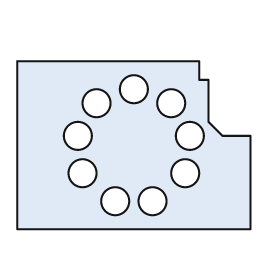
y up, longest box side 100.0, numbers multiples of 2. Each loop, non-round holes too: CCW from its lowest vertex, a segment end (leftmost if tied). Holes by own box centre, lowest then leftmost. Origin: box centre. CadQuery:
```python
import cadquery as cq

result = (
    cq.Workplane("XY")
    .moveTo(-50.0, -36.0)
    .lineTo(50.0, -36.0)
    .lineTo(50.0, 4.0)
    .lineTo(38.0, 4.0)
    .lineTo(32.0, 10.0)
    .lineTo(32.0, 28.0)
    .lineTo(28.0, 28.0)
    .lineTo(28.0, 36.0)
    .lineTo(-50.0, 36.0)
    .close()
    .moveTo(-8.0, -24.0)
    .circle(6.0)
    .moveTo(8.0, -24.0)
    .circle(6.0)
    .moveTo(-22.0, -12.0)
    .circle(6.0)
    .moveTo(22.0, -12.0)
    .circle(6.0)
    .moveTo(-24.0, 4.0)
    .circle(6.0)
    .moveTo(24.0, 4.0)
    .circle(6.0)
    .moveTo(-16.0, 18.0)
    .circle(6.0)
    .moveTo(16.0, 18.0)
    .circle(6.0)
    .moveTo(0.0, 24.0)
    .circle(6.0)
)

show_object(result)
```